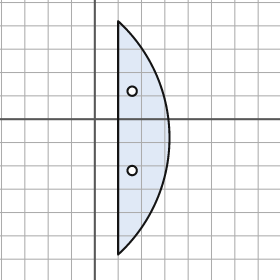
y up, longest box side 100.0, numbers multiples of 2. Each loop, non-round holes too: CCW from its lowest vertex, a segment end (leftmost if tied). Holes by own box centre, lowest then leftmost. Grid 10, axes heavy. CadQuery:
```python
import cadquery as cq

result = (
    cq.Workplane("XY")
    .moveTo(10.0, -58.0)
    .threePointArc((32.0, -8.0), (10.0, 42.0))
    .close()
    .moveTo(16.0, -22.0)
    .circle(2.0)
    .moveTo(16.0, 12.0)
    .circle(2.0)
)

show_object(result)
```